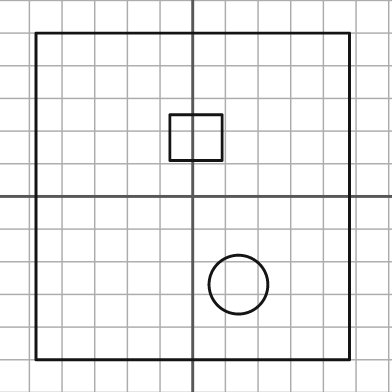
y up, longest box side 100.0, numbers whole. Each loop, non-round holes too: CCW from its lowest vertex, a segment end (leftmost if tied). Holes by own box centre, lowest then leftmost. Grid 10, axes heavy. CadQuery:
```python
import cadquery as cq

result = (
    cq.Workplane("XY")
    .moveTo(-48.0, -50.0)
    .lineTo(48.0, -50.0)
    .lineTo(48.0, 50.0)
    .lineTo(-48.0, 50.0)
    .close()
    .moveTo(14.0, -27.0)
    .circle(9.0)
    .moveTo(-7.0, 11.0)
    .lineTo(9.0, 11.0)
    .lineTo(9.0, 25.0)
    .lineTo(-7.0, 25.0)
    .close()
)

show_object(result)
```